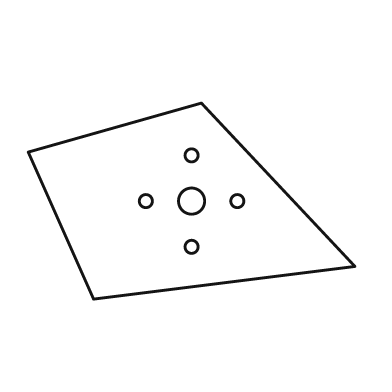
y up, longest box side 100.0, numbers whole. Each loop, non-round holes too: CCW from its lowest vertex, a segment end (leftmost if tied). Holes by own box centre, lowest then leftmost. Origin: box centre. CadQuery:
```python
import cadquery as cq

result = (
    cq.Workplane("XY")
    .moveTo(-30.0, -30.0)
    .lineTo(50.0, -20.0)
    .lineTo(3.0, 30.0)
    .lineTo(-50.0, 15.0)
    .close()
    .moveTo(0.0, -14.0)
    .circle(2.0)
    .moveTo(-14.0, 0.0)
    .circle(2.0)
    .moveTo(0.0, 0.0)
    .circle(4.0)
    .moveTo(14.0, 0.0)
    .circle(2.0)
    .moveTo(0.0, 14.0)
    .circle(2.0)
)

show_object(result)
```